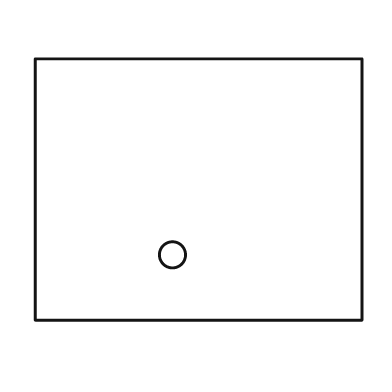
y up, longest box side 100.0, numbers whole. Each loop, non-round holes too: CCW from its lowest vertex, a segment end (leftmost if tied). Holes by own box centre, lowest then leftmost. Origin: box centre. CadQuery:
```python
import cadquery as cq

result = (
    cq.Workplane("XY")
    .moveTo(-50.0, -40.0)
    .lineTo(50.0, -40.0)
    .lineTo(50.0, 40.0)
    .lineTo(-50.0, 40.0)
    .close()
    .moveTo(-8.0, -20.0)
    .circle(4.0)
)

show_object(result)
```